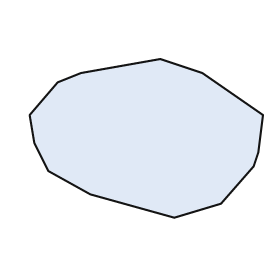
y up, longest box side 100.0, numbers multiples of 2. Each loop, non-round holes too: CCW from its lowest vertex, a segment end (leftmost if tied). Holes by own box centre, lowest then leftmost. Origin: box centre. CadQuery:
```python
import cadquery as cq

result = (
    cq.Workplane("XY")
    .moveTo(12.0, -34.0)
    .lineTo(32.0, -28.0)
    .lineTo(46.0, -12.0)
    .lineTo(48.0, -6.0)
    .lineTo(50.0, 10.0)
    .lineTo(24.0, 28.0)
    .lineTo(6.0, 34.0)
    .lineTo(-28.0, 28.0)
    .lineTo(-38.0, 24.0)
    .lineTo(-50.0, 10.0)
    .lineTo(-48.0, -2.0)
    .lineTo(-42.0, -14.0)
    .lineTo(-24.0, -24.0)
    .close()
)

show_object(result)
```